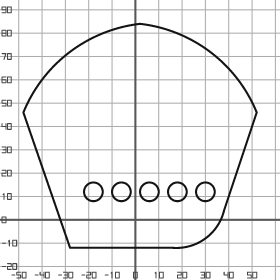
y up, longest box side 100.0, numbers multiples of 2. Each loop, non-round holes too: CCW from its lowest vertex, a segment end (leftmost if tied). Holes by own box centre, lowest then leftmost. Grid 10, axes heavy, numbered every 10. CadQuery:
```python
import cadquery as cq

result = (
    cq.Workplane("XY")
    .moveTo(-28.0, -12.0)
    .lineTo(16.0, -12.0)
    .threePointArc((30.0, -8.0), (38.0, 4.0))
    .lineTo(52.0, 46.0)
    .threePointArc((32.0, 72.0), (2.0, 84.0))
    .threePointArc((-28.0, 72.0), (-48.0, 46.0))
    .close()
    .moveTo(-18.0, 12.0)
    .circle(4.0)
    .moveTo(-6.0, 12.0)
    .circle(4.0)
    .moveTo(6.0, 12.0)
    .circle(4.0)
    .moveTo(18.0, 12.0)
    .circle(4.0)
    .moveTo(30.0, 12.0)
    .circle(4.0)
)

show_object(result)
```